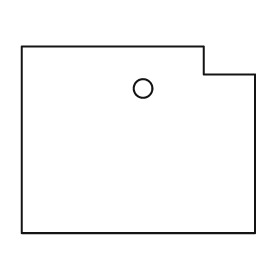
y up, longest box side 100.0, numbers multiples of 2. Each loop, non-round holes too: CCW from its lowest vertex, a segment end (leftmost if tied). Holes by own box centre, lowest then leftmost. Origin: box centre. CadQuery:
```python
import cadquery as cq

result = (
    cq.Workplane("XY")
    .moveTo(-50.0, -40.0)
    .lineTo(50.0, -40.0)
    .lineTo(50.0, 28.0)
    .lineTo(28.0, 28.0)
    .lineTo(28.0, 40.0)
    .lineTo(-50.0, 40.0)
    .close()
    .moveTo(2.0, 22.0)
    .circle(4.0)
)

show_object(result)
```